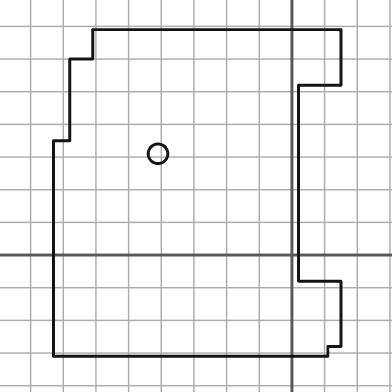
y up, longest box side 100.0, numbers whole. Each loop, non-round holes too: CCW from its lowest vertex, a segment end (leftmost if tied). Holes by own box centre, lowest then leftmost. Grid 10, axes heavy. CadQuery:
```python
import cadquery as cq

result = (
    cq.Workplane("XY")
    .moveTo(-73.0, -31.0)
    .lineTo(11.0, -31.0)
    .lineTo(11.0, -28.0)
    .lineTo(15.0, -28.0)
    .lineTo(15.0, -8.0)
    .lineTo(2.0, -8.0)
    .lineTo(2.0, 52.0)
    .lineTo(15.0, 52.0)
    .lineTo(15.0, 69.0)
    .lineTo(-61.0, 69.0)
    .lineTo(-61.0, 60.0)
    .lineTo(-68.0, 60.0)
    .lineTo(-68.0, 35.0)
    .lineTo(-73.0, 35.0)
    .close()
    .moveTo(-41.0, 31.0)
    .circle(3.0)
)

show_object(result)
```